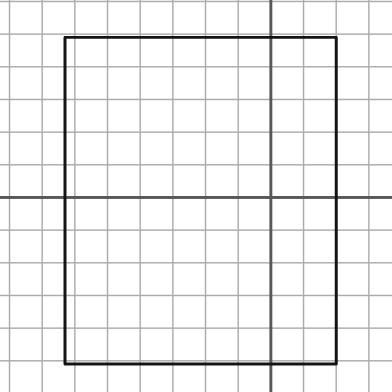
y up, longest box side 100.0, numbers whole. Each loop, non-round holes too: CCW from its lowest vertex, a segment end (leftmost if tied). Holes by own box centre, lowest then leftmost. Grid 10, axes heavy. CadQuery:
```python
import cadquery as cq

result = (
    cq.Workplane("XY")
    .moveTo(-63.0, -51.0)
    .lineTo(20.0, -51.0)
    .lineTo(20.0, 49.0)
    .lineTo(-63.0, 49.0)
    .close()
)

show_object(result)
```